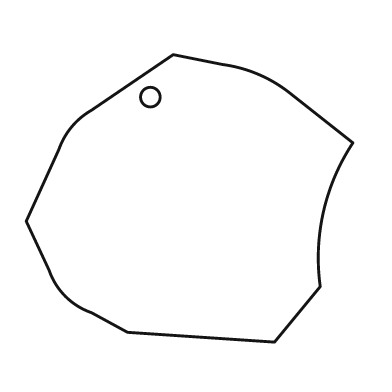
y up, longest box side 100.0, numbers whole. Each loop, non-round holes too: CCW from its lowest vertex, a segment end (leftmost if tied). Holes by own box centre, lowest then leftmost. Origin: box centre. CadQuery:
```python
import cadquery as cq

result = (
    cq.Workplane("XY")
    .moveTo(26.0, -44.0)
    .lineTo(40.0, -27.0)
    .threePointArc((41.0, -4.0), (50.0, 17.0))
    .lineTo(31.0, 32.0)
    .threePointArc((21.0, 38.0), (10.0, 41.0))
    .lineTo(-5.0, 44.0)
    .lineTo(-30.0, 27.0)
    .threePointArc((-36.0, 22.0), (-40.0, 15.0))
    .lineTo(-50.0, -7.0)
    .lineTo(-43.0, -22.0)
    .threePointArc((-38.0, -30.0), (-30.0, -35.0))
    .lineTo(-19.0, -41.0)
    .close()
    .moveTo(-12.0, 31.0)
    .circle(3.0)
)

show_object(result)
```